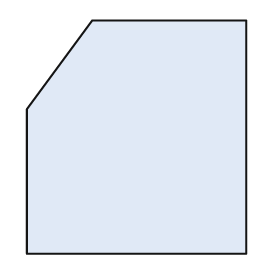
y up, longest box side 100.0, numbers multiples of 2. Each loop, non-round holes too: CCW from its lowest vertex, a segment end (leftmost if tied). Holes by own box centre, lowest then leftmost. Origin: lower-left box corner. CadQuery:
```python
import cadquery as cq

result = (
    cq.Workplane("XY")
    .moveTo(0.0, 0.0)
    .lineTo(94.0, 0.0)
    .lineTo(94.0, 100.0)
    .lineTo(28.0, 100.0)
    .lineTo(0.0, 62.0)
    .close()
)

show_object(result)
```